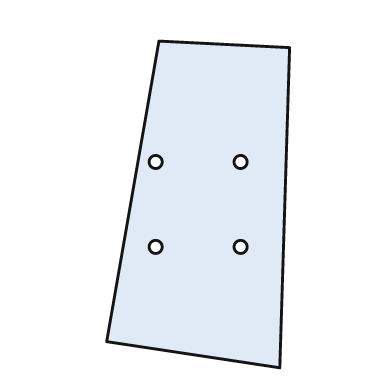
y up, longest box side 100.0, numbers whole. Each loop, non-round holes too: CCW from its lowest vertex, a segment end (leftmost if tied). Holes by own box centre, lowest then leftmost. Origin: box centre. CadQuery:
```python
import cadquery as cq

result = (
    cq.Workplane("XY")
    .moveTo(25.0, -50.0)
    .lineTo(28.0, 48.0)
    .lineTo(-12.0, 50.0)
    .lineTo(-28.0, -42.0)
    .close()
    .moveTo(-13.0, -13.0)
    .circle(2.0)
    .moveTo(13.0, -13.0)
    .circle(2.0)
    .moveTo(-13.0, 13.0)
    .circle(2.0)
    .moveTo(13.0, 13.0)
    .circle(2.0)
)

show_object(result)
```